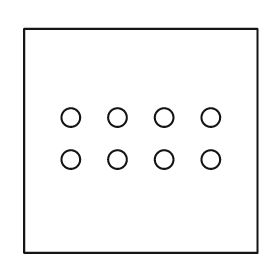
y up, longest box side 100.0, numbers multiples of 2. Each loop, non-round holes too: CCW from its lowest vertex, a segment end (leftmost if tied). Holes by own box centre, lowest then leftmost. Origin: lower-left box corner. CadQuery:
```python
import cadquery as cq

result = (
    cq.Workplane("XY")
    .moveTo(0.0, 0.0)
    .lineTo(100.0, 0.0)
    .lineTo(100.0, 96.0)
    .lineTo(0.0, 96.0)
    .close()
    .moveTo(20.0, 40.0)
    .circle(4.0)
    .moveTo(40.0, 40.0)
    .circle(4.0)
    .moveTo(60.0, 40.0)
    .circle(4.0)
    .moveTo(80.0, 40.0)
    .circle(4.0)
    .moveTo(20.0, 58.0)
    .circle(4.0)
    .moveTo(40.0, 58.0)
    .circle(4.0)
    .moveTo(60.0, 58.0)
    .circle(4.0)
    .moveTo(80.0, 58.0)
    .circle(4.0)
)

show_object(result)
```